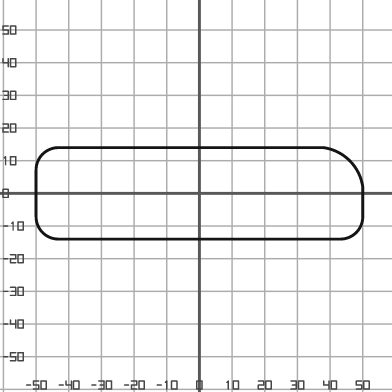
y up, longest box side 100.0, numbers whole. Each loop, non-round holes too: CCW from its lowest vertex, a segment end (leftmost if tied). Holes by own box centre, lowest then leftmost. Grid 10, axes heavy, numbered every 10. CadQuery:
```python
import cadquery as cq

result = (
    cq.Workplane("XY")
    .moveTo(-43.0, -14.0)
    .lineTo(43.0, -14.0)
    .threePointArc((48.0, -12.0), (50.0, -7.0))
    .lineTo(50.0, 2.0)
    .threePointArc((46.0, 10.0), (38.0, 14.0))
    .lineTo(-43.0, 14.0)
    .threePointArc((-48.0, 12.0), (-50.0, 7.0))
    .lineTo(-50.0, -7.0)
    .threePointArc((-48.0, -12.0), (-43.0, -14.0))
    .close()
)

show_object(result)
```